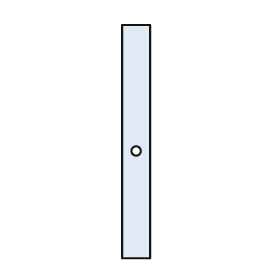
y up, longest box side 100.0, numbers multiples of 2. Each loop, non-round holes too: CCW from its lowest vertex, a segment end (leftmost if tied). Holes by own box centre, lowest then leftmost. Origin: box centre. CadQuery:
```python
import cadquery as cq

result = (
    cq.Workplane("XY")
    .moveTo(-6.0, -50.0)
    .lineTo(6.0, -50.0)
    .lineTo(6.0, 50.0)
    .lineTo(-6.0, 50.0)
    .close()
    .moveTo(0.0, -4.0)
    .circle(2.0)
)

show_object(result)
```